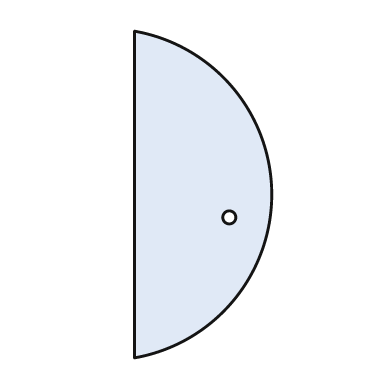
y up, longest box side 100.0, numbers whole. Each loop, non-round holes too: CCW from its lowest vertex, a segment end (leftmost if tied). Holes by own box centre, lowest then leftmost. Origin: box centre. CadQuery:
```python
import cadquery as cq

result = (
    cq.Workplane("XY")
    .moveTo(-21.0, -50.0)
    .threePointArc((21.0, 0.0), (-21.0, 50.0))
    .close()
    .moveTo(8.0, -7.0)
    .circle(2.0)
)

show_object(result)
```